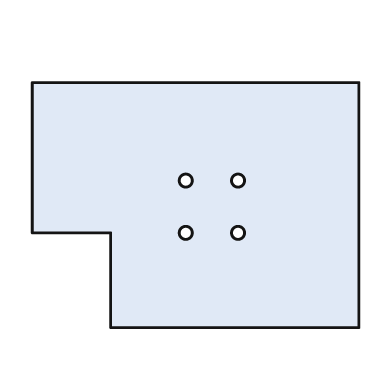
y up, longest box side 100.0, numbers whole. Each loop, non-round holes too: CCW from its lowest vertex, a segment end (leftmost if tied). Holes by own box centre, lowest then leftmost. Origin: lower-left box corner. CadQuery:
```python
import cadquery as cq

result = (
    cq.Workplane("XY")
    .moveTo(24.0, 0.0)
    .lineTo(100.0, 0.0)
    .lineTo(100.0, 75.0)
    .lineTo(0.0, 75.0)
    .lineTo(0.0, 29.0)
    .lineTo(24.0, 29.0)
    .close()
    .moveTo(47.0, 29.0)
    .circle(2.0)
    .moveTo(63.0, 29.0)
    .circle(2.0)
    .moveTo(47.0, 45.0)
    .circle(2.0)
    .moveTo(63.0, 45.0)
    .circle(2.0)
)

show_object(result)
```